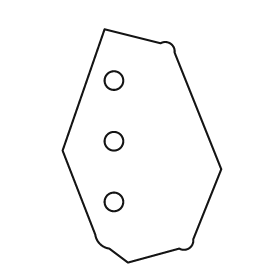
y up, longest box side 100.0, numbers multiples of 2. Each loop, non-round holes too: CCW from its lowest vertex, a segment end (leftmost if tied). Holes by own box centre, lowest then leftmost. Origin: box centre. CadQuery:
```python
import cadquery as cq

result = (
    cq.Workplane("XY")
    .moveTo(-6.0, -50.0)
    .lineTo(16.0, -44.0)
    .threePointArc((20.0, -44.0), (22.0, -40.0))
    .lineTo(34.0, -10.0)
    .lineTo(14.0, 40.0)
    .threePointArc((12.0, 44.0), (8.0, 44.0))
    .lineTo(-16.0, 50.0)
    .lineTo(-34.0, -2.0)
    .lineTo(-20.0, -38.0)
    .threePointArc((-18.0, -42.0), (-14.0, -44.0))
    .close()
    .moveTo(-12.0, -24.0)
    .circle(4.0)
    .moveTo(-12.0, 2.0)
    .circle(4.0)
    .moveTo(-12.0, 28.0)
    .circle(4.0)
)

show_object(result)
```